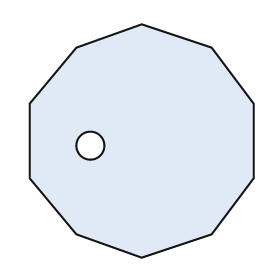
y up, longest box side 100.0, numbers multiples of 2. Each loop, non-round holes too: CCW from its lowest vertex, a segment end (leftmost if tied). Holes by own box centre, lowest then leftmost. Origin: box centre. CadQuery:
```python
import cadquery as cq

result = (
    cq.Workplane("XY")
    .moveTo(0.0, -50.0)
    .lineTo(30.0, -40.0)
    .lineTo(48.0, -16.0)
    .lineTo(48.0, 16.0)
    .lineTo(30.0, 40.0)
    .lineTo(0.0, 50.0)
    .lineTo(-28.0, 40.0)
    .lineTo(-48.0, 16.0)
    .lineTo(-48.0, -16.0)
    .lineTo(-28.0, -40.0)
    .close()
    .moveTo(-22.0, -2.0)
    .circle(6.0)
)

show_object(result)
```